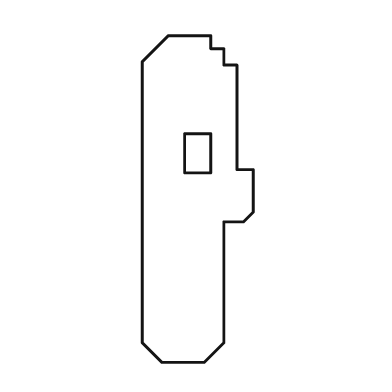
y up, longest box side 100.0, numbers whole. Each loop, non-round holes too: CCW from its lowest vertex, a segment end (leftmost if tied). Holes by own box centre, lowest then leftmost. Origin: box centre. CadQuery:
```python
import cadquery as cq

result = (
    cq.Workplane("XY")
    .moveTo(-11.0, -50.0)
    .lineTo(2.0, -50.0)
    .lineTo(8.0, -44.0)
    .lineTo(8.0, -7.0)
    .lineTo(14.0, -7.0)
    .lineTo(17.0, -4.0)
    .lineTo(17.0, 9.0)
    .lineTo(12.0, 9.0)
    .lineTo(12.0, 41.0)
    .lineTo(8.0, 41.0)
    .lineTo(8.0, 46.0)
    .lineTo(4.0, 46.0)
    .lineTo(4.0, 50.0)
    .lineTo(-9.0, 50.0)
    .lineTo(-17.0, 42.0)
    .lineTo(-17.0, -44.0)
    .close()
    .moveTo(-4.0, 8.0)
    .lineTo(4.0, 8.0)
    .lineTo(4.0, 20.0)
    .lineTo(-4.0, 20.0)
    .close()
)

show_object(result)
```